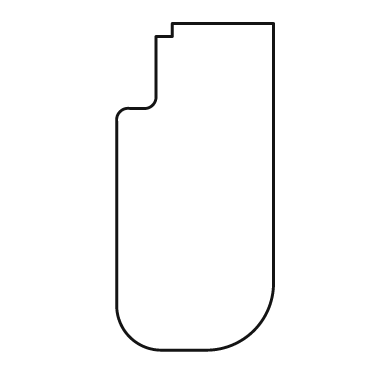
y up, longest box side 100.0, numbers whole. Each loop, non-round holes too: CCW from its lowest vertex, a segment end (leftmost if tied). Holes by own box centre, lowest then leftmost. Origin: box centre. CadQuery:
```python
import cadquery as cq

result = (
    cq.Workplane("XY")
    .moveTo(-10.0, -50.0)
    .lineTo(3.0, -50.0)
    .threePointArc((18.0, -44.0), (24.0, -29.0))
    .lineTo(24.0, 50.0)
    .lineTo(-7.0, 50.0)
    .lineTo(-7.0, 46.0)
    .lineTo(-12.0, 46.0)
    .lineTo(-12.0, 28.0)
    .threePointArc((-13.0, 25.0), (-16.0, 24.0))
    .lineTo(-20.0, 24.0)
    .threePointArc((-23.0, 23.0), (-24.0, 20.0))
    .lineTo(-24.0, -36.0)
    .threePointArc((-20.0, -46.0), (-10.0, -50.0))
    .close()
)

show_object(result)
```